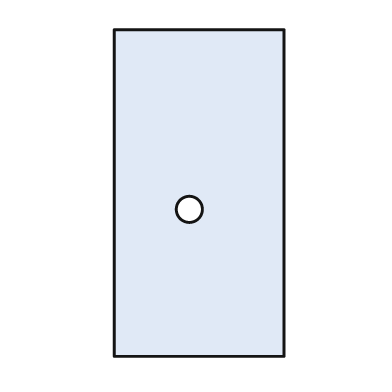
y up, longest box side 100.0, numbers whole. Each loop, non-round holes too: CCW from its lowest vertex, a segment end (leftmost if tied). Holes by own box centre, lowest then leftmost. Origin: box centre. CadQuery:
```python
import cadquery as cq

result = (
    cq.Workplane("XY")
    .moveTo(-26.0, -50.0)
    .lineTo(26.0, -50.0)
    .lineTo(26.0, 50.0)
    .lineTo(-26.0, 50.0)
    .close()
    .moveTo(-3.0, -5.0)
    .circle(4.0)
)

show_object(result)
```